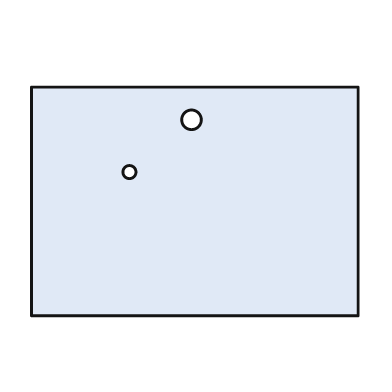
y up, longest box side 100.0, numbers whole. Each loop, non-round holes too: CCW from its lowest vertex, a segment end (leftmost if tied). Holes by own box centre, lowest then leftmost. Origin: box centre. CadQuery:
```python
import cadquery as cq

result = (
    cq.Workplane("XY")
    .moveTo(-50.0, -35.0)
    .lineTo(50.0, -35.0)
    .lineTo(50.0, 35.0)
    .lineTo(-50.0, 35.0)
    .close()
    .moveTo(-20.0, 9.0)
    .circle(2.0)
    .moveTo(-1.0, 25.0)
    .circle(3.0)
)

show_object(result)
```